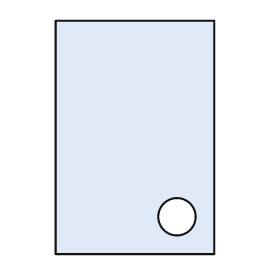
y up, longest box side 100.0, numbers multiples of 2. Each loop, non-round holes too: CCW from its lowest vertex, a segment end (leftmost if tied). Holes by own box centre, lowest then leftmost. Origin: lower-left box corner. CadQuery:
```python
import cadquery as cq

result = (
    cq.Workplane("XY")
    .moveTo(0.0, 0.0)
    .lineTo(68.0, 0.0)
    .lineTo(68.0, 100.0)
    .lineTo(0.0, 100.0)
    .close()
    .moveTo(52.0, 16.0)
    .circle(8.0)
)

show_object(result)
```